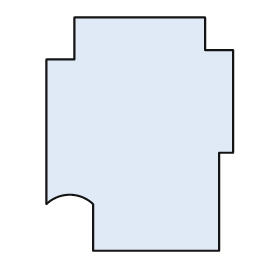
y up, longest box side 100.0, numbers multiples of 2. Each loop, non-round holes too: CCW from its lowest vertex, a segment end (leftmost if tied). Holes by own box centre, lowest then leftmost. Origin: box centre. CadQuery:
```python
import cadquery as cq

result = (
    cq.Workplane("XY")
    .moveTo(-20.0, -50.0)
    .lineTo(34.0, -50.0)
    .lineTo(34.0, -8.0)
    .lineTo(40.0, -8.0)
    .lineTo(40.0, 36.0)
    .lineTo(28.0, 36.0)
    .lineTo(28.0, 50.0)
    .lineTo(-28.0, 50.0)
    .lineTo(-28.0, 32.0)
    .lineTo(-40.0, 32.0)
    .lineTo(-40.0, -30.0)
    .threePointArc((-30.0, -26.0), (-20.0, -30.0))
    .close()
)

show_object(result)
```